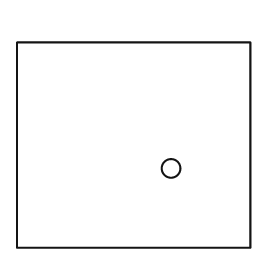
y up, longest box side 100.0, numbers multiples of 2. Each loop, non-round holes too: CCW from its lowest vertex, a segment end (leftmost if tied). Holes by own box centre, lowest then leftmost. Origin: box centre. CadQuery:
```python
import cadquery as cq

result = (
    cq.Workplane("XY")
    .moveTo(-50.0, -44.0)
    .lineTo(50.0, -44.0)
    .lineTo(50.0, 44.0)
    .lineTo(-50.0, 44.0)
    .close()
    .moveTo(16.0, -10.0)
    .circle(4.0)
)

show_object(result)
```